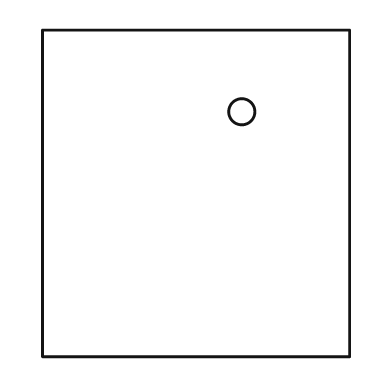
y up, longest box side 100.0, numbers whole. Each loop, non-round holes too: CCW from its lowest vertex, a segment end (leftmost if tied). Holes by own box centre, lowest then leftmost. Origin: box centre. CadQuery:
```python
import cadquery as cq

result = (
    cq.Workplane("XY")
    .moveTo(-47.0, -50.0)
    .lineTo(47.0, -50.0)
    .lineTo(47.0, 50.0)
    .lineTo(-47.0, 50.0)
    .close()
    .moveTo(14.0, 25.0)
    .circle(4.0)
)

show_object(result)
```